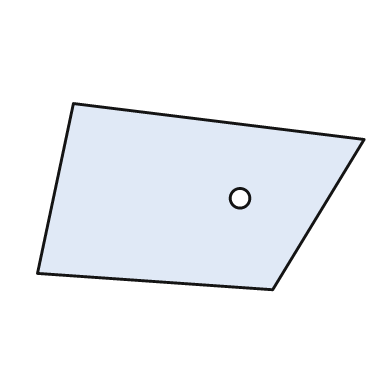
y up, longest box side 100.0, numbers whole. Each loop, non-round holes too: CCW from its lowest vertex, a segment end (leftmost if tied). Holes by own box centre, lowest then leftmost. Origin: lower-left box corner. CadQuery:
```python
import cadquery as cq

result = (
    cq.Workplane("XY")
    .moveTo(72.0, 0.0)
    .lineTo(100.0, 46.0)
    .lineTo(11.0, 57.0)
    .lineTo(0.0, 5.0)
    .close()
    .moveTo(62.0, 28.0)
    .circle(3.0)
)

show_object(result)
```